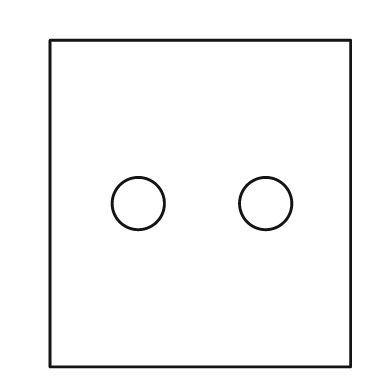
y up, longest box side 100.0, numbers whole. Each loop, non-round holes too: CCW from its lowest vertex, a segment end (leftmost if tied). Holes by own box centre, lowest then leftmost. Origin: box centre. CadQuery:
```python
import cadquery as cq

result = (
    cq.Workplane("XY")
    .moveTo(-46.0, -50.0)
    .lineTo(46.0, -50.0)
    .lineTo(46.0, 50.0)
    .lineTo(-46.0, 50.0)
    .close()
    .moveTo(-19.0, 0.0)
    .circle(8.0)
    .moveTo(20.0, 0.0)
    .circle(8.0)
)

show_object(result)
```